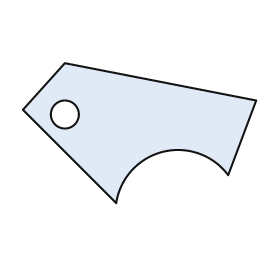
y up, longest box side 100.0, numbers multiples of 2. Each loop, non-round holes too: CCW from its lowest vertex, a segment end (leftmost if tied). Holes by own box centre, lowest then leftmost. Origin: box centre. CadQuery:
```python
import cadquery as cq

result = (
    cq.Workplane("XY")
    .moveTo(-10.0, -30.0)
    .threePointArc((10.0, -8.0), (38.0, -18.0))
    .lineTo(50.0, 14.0)
    .lineTo(-32.0, 30.0)
    .lineTo(-50.0, 10.0)
    .close()
    .moveTo(-32.0, 8.0)
    .circle(6.0)
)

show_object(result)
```